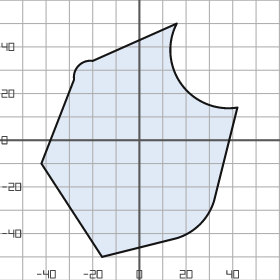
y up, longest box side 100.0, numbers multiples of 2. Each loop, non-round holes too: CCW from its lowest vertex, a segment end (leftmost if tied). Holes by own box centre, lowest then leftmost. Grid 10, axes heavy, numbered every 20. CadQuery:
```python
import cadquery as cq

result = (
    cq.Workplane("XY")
    .moveTo(-16.0, -50.0)
    .lineTo(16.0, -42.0)
    .threePointArc((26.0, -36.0), (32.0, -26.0))
    .lineTo(42.0, 14.0)
    .threePointArc((18.0, 24.0), (16.0, 50.0))
    .lineTo(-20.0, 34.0)
    .threePointArc((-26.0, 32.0), (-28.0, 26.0))
    .lineTo(-42.0, -10.0)
    .close()
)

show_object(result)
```